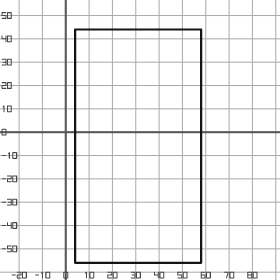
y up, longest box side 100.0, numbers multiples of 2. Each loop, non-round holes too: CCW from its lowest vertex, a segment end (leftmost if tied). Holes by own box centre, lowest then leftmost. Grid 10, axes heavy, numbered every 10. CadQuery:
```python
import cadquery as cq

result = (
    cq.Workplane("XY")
    .moveTo(4.0, -56.0)
    .lineTo(58.0, -56.0)
    .lineTo(58.0, 44.0)
    .lineTo(4.0, 44.0)
    .close()
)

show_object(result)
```